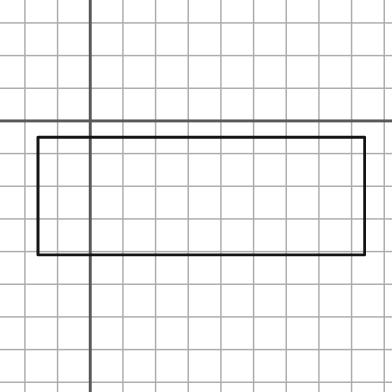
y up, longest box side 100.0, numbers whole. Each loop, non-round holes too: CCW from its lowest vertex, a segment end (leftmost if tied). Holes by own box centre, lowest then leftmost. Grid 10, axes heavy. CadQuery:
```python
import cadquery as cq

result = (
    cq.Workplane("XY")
    .moveTo(-16.0, -41.0)
    .lineTo(84.0, -41.0)
    .lineTo(84.0, -5.0)
    .lineTo(-16.0, -5.0)
    .close()
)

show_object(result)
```